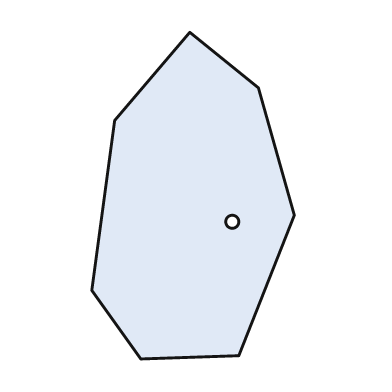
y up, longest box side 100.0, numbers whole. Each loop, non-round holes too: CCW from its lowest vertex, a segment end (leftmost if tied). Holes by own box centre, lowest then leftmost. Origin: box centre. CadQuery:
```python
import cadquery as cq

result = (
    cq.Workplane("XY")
    .moveTo(-16.0, -50.0)
    .lineTo(14.0, -49.0)
    .lineTo(31.0, -6.0)
    .lineTo(20.0, 33.0)
    .lineTo(-1.0, 50.0)
    .lineTo(-24.0, 23.0)
    .lineTo(-31.0, -29.0)
    .close()
    .moveTo(12.0, -8.0)
    .circle(2.0)
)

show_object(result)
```